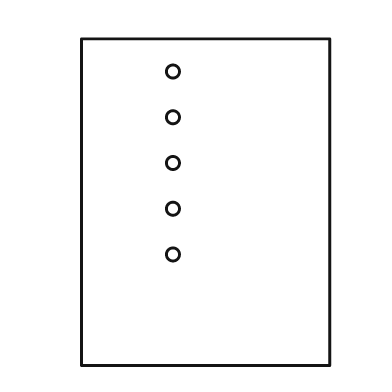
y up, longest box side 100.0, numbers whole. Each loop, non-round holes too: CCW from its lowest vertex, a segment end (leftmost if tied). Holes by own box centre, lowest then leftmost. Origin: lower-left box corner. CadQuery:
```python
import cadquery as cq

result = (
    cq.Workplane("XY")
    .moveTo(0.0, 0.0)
    .lineTo(76.0, 0.0)
    .lineTo(76.0, 100.0)
    .lineTo(0.0, 100.0)
    .close()
    .moveTo(28.0, 34.0)
    .circle(2.0)
    .moveTo(28.0, 48.0)
    .circle(2.0)
    .moveTo(28.0, 62.0)
    .circle(2.0)
    .moveTo(28.0, 76.0)
    .circle(2.0)
    .moveTo(28.0, 90.0)
    .circle(2.0)
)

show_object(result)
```